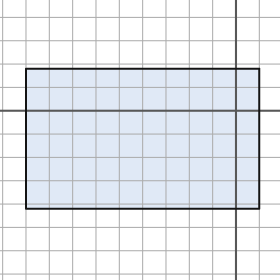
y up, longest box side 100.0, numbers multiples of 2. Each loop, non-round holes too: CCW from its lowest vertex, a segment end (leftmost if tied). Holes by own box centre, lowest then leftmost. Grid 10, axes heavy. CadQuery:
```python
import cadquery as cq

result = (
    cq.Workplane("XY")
    .moveTo(-90.0, -42.0)
    .lineTo(10.0, -42.0)
    .lineTo(10.0, 18.0)
    .lineTo(-90.0, 18.0)
    .close()
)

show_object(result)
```